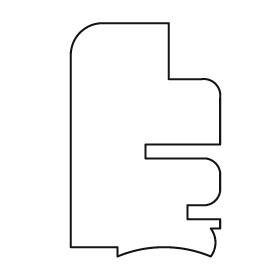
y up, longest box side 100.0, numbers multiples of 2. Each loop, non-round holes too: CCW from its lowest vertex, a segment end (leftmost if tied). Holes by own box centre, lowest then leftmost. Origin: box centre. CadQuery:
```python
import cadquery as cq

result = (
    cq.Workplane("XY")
    .moveTo(-12.0, -50.0)
    .threePointArc((8.0, -46.0), (28.0, -50.0))
    .threePointArc((30.0, -44.0), (28.0, -38.0))
    .lineTo(32.0, -38.0)
    .lineTo(32.0, -34.0)
    .lineTo(18.0, -34.0)
    .lineTo(18.0, -28.0)
    .lineTo(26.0, -28.0)
    .threePointArc((30.0, -26.0), (32.0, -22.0))
    .lineTo(32.0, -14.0)
    .threePointArc((30.0, -10.0), (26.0, -8.0))
    .lineTo(0.0, -8.0)
    .lineTo(0.0, -2.0)
    .lineTo(32.0, -2.0)
    .lineTo(32.0, 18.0)
    .threePointArc((30.0, 24.0), (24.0, 26.0))
    .lineTo(10.0, 26.0)
    .lineTo(10.0, 50.0)
    .lineTo(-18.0, 50.0)
    .threePointArc((-28.0, 46.0), (-32.0, 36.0))
    .lineTo(-32.0, -46.0)
    .lineTo(-12.0, -46.0)
    .close()
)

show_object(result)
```